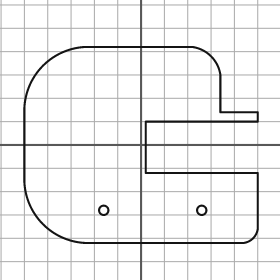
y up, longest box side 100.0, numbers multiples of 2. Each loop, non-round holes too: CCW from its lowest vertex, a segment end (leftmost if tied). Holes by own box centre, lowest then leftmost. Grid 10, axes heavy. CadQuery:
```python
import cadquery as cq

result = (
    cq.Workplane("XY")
    .moveTo(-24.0, -42.0)
    .lineTo(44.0, -42.0)
    .threePointArc((48.0, -40.0), (50.0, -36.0))
    .lineTo(50.0, -12.0)
    .lineTo(2.0, -12.0)
    .lineTo(2.0, 10.0)
    .lineTo(50.0, 10.0)
    .lineTo(50.0, 14.0)
    .lineTo(34.0, 14.0)
    .lineTo(34.0, 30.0)
    .threePointArc((30.0, 38.0), (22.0, 42.0))
    .lineTo(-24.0, 42.0)
    .threePointArc((-42.0, 34.0), (-50.0, 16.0))
    .lineTo(-50.0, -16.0)
    .threePointArc((-42.0, -34.0), (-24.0, -42.0))
    .close()
    .moveTo(-16.0, -28.0)
    .circle(2.0)
    .moveTo(26.0, -28.0)
    .circle(2.0)
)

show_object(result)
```